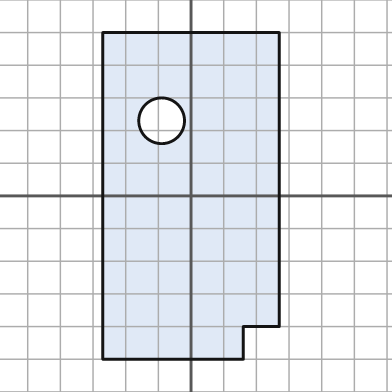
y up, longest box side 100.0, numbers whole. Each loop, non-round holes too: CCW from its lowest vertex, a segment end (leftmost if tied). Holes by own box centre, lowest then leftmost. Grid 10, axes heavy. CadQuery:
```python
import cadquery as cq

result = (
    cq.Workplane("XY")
    .moveTo(-27.0, -50.0)
    .lineTo(16.0, -50.0)
    .lineTo(16.0, -40.0)
    .lineTo(27.0, -40.0)
    .lineTo(27.0, 50.0)
    .lineTo(-27.0, 50.0)
    .close()
    .moveTo(-9.0, 23.0)
    .circle(7.0)
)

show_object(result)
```